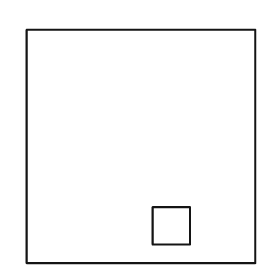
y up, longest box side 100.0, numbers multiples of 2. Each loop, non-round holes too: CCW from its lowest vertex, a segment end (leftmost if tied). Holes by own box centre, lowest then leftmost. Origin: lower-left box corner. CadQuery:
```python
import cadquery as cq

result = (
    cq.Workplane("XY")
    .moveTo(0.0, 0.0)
    .lineTo(98.0, 0.0)
    .lineTo(98.0, 100.0)
    .lineTo(0.0, 100.0)
    .close()
    .moveTo(54.0, 8.0)
    .lineTo(70.0, 8.0)
    .lineTo(70.0, 24.0)
    .lineTo(54.0, 24.0)
    .close()
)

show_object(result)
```